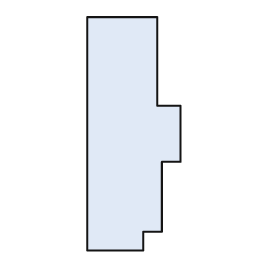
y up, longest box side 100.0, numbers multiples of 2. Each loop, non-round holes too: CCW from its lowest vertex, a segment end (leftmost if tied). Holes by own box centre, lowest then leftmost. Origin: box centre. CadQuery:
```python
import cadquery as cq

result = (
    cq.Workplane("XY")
    .moveTo(-20.0, -50.0)
    .lineTo(4.0, -50.0)
    .lineTo(4.0, -42.0)
    .lineTo(12.0, -42.0)
    .lineTo(12.0, -12.0)
    .lineTo(20.0, -12.0)
    .lineTo(20.0, 12.0)
    .lineTo(10.0, 12.0)
    .lineTo(10.0, 50.0)
    .lineTo(-20.0, 50.0)
    .close()
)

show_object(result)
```